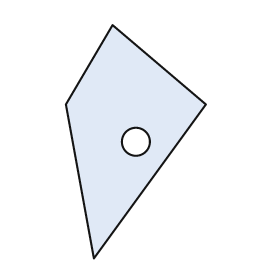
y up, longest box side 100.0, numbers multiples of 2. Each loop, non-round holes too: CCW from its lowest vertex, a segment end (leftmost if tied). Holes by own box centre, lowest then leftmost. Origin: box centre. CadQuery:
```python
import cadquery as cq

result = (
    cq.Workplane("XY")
    .moveTo(-18.0, -50.0)
    .lineTo(30.0, 16.0)
    .lineTo(-10.0, 50.0)
    .lineTo(-30.0, 16.0)
    .close()
    .moveTo(0.0, 0.0)
    .circle(6.0)
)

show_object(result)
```